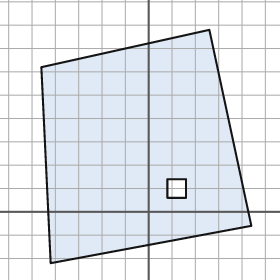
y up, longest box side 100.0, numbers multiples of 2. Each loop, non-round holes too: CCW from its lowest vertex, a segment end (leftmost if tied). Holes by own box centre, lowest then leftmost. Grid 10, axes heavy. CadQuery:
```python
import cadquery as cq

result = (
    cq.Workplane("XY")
    .moveTo(-42.0, -22.0)
    .lineTo(44.0, -6.0)
    .lineTo(26.0, 78.0)
    .lineTo(-46.0, 62.0)
    .close()
    .moveTo(8.0, 6.0)
    .lineTo(16.0, 6.0)
    .lineTo(16.0, 14.0)
    .lineTo(8.0, 14.0)
    .close()
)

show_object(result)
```